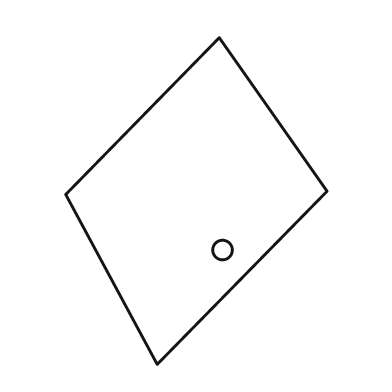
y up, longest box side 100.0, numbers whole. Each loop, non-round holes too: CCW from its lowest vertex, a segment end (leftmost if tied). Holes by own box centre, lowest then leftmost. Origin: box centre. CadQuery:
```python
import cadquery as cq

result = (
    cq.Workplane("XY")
    .moveTo(-12.0, -50.0)
    .lineTo(40.0, 3.0)
    .lineTo(7.0, 50.0)
    .lineTo(-40.0, 2.0)
    .close()
    .moveTo(8.0, -15.0)
    .circle(3.0)
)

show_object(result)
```